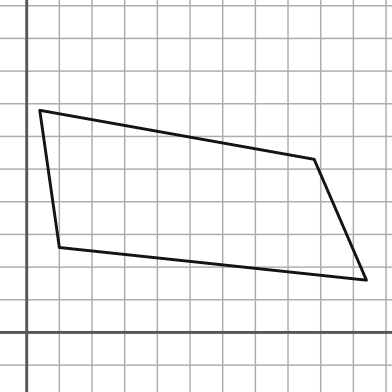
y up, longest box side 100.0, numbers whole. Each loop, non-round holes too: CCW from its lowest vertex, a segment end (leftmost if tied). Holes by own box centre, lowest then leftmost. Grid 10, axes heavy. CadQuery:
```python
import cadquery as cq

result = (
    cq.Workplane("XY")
    .moveTo(104.0, 16.0)
    .lineTo(88.0, 53.0)
    .lineTo(4.0, 68.0)
    .lineTo(10.0, 26.0)
    .close()
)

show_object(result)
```